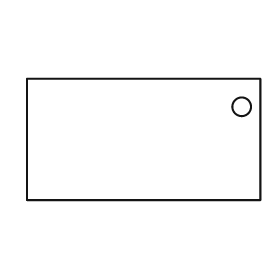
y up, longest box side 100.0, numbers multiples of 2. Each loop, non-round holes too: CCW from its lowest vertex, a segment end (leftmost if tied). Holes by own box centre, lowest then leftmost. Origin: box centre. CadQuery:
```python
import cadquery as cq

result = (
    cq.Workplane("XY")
    .moveTo(-50.0, -26.0)
    .lineTo(50.0, -26.0)
    .lineTo(50.0, 26.0)
    .lineTo(-50.0, 26.0)
    .close()
    .moveTo(42.0, 14.0)
    .circle(4.0)
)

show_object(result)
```